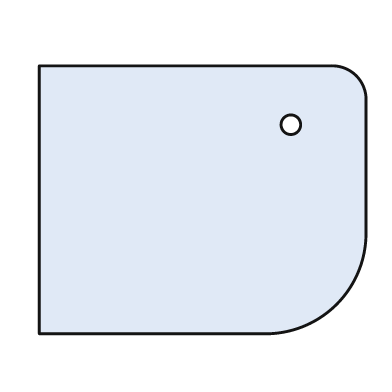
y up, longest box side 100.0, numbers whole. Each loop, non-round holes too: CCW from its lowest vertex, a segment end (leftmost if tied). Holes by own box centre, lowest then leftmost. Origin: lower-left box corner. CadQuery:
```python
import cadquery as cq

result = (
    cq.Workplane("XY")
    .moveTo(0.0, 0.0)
    .lineTo(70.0, 0.0)
    .threePointArc((91.0, 9.0), (100.0, 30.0))
    .lineTo(100.0, 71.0)
    .threePointArc((97.0, 79.0), (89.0, 82.0))
    .lineTo(0.0, 82.0)
    .close()
    .moveTo(77.0, 64.0)
    .circle(3.0)
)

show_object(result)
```